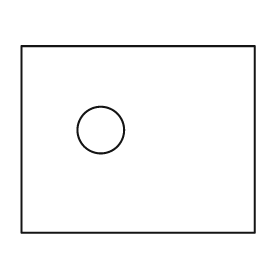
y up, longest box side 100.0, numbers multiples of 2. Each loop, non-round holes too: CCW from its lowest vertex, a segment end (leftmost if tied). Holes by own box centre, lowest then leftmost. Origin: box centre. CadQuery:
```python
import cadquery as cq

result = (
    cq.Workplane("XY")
    .moveTo(-50.0, -40.0)
    .lineTo(50.0, -40.0)
    .lineTo(50.0, 40.0)
    .lineTo(-50.0, 40.0)
    .close()
    .moveTo(-16.0, 4.0)
    .circle(10.0)
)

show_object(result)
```